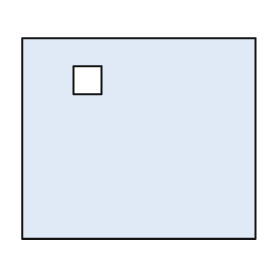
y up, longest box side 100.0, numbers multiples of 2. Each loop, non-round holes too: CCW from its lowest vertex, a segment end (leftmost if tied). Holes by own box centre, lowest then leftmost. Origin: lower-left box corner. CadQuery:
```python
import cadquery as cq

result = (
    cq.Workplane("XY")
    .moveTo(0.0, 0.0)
    .lineTo(100.0, 0.0)
    .lineTo(100.0, 86.0)
    .lineTo(0.0, 86.0)
    .close()
    .moveTo(22.0, 62.0)
    .lineTo(34.0, 62.0)
    .lineTo(34.0, 74.0)
    .lineTo(22.0, 74.0)
    .close()
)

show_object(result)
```